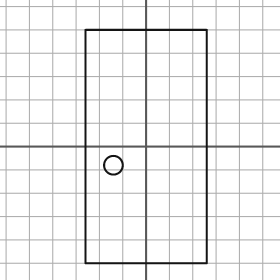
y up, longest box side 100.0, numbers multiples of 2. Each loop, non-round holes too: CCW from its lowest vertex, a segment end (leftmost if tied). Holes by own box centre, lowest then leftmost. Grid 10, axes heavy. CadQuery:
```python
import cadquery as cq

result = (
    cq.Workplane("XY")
    .moveTo(-26.0, -50.0)
    .lineTo(26.0, -50.0)
    .lineTo(26.0, 50.0)
    .lineTo(-26.0, 50.0)
    .close()
    .moveTo(-14.0, -8.0)
    .circle(4.0)
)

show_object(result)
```